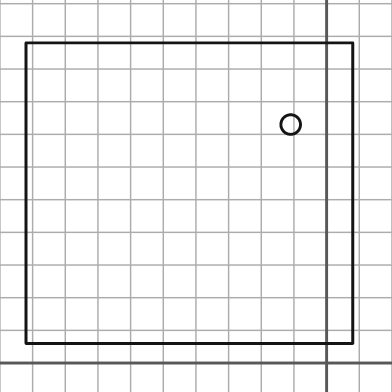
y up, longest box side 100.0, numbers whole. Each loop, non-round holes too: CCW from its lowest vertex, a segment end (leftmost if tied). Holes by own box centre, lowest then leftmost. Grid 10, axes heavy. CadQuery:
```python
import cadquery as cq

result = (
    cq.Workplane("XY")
    .moveTo(-92.0, 6.0)
    .lineTo(8.0, 6.0)
    .lineTo(8.0, 98.0)
    .lineTo(-92.0, 98.0)
    .close()
    .moveTo(-11.0, 73.0)
    .circle(3.0)
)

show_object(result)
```